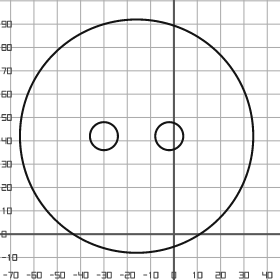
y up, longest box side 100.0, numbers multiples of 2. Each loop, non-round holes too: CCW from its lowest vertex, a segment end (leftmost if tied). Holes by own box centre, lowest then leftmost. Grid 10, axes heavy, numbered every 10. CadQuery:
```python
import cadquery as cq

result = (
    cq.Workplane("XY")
    .moveTo(-16.0, 42.0)
    .circle(50.0)
    .moveTo(-30.0, 42.0)
    .circle(6.0)
    .moveTo(-2.0, 42.0)
    .circle(6.0)
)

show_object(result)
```